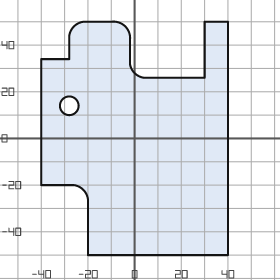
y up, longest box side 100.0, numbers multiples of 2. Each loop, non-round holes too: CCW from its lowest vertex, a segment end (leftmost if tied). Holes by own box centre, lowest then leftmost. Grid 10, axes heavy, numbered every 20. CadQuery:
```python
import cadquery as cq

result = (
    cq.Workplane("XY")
    .moveTo(-20.0, -50.0)
    .lineTo(40.0, -50.0)
    .lineTo(40.0, 50.0)
    .lineTo(30.0, 50.0)
    .lineTo(30.0, 26.0)
    .lineTo(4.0, 26.0)
    .threePointArc((0.0, 28.0), (-2.0, 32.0))
    .lineTo(-2.0, 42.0)
    .threePointArc((-4.0, 48.0), (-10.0, 50.0))
    .lineTo(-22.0, 50.0)
    .threePointArc((-26.0, 48.0), (-28.0, 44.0))
    .lineTo(-28.0, 34.0)
    .lineTo(-40.0, 34.0)
    .lineTo(-40.0, -20.0)
    .lineTo(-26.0, -20.0)
    .threePointArc((-22.0, -22.0), (-20.0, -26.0))
    .close()
    .moveTo(-28.0, 14.0)
    .circle(4.0)
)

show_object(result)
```